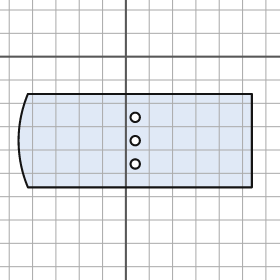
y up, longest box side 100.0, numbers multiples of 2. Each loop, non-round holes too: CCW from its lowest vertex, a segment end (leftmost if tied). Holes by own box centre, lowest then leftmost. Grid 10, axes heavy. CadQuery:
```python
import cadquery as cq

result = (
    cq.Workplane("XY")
    .moveTo(-42.0, -56.0)
    .lineTo(54.0, -56.0)
    .lineTo(54.0, -16.0)
    .lineTo(-42.0, -16.0)
    .threePointArc((-46.0, -36.0), (-42.0, -56.0))
    .close()
    .moveTo(4.0, -46.0)
    .circle(2.0)
    .moveTo(4.0, -36.0)
    .circle(2.0)
    .moveTo(4.0, -26.0)
    .circle(2.0)
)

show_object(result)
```